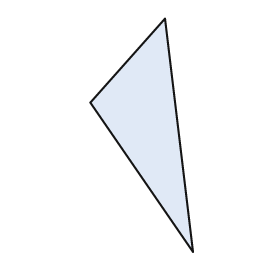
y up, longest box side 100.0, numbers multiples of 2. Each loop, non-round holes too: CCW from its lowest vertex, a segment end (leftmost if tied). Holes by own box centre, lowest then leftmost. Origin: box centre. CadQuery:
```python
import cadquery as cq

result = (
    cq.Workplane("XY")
    .moveTo(22.0, -50.0)
    .lineTo(10.0, 50.0)
    .lineTo(-22.0, 14.0)
    .close()
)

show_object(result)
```